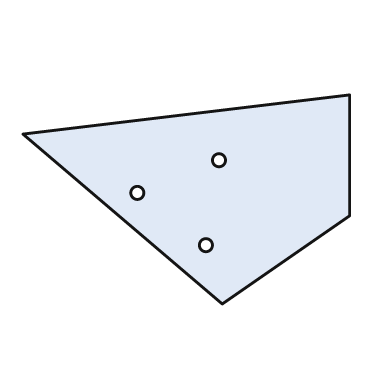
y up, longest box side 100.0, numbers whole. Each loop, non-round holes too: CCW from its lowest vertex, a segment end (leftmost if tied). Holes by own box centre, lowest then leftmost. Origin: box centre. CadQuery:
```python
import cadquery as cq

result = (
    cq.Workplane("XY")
    .moveTo(11.0, -32.0)
    .lineTo(50.0, -5.0)
    .lineTo(50.0, 32.0)
    .lineTo(-50.0, 20.0)
    .close()
    .moveTo(6.0, -14.0)
    .circle(2.0)
    .moveTo(-15.0, 2.0)
    .circle(2.0)
    .moveTo(10.0, 12.0)
    .circle(2.0)
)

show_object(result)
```